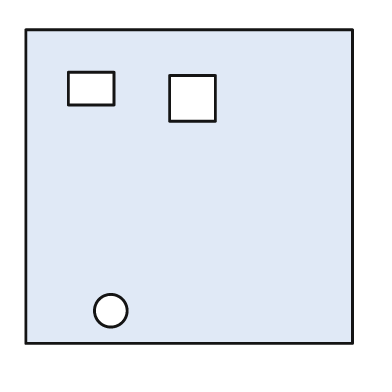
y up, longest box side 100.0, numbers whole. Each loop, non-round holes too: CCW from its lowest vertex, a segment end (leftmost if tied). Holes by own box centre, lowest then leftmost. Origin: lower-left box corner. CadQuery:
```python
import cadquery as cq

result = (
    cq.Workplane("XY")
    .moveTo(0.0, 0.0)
    .lineTo(100.0, 0.0)
    .lineTo(100.0, 96.0)
    .lineTo(0.0, 96.0)
    .close()
    .moveTo(26.0, 10.0)
    .circle(5.0)
    .moveTo(44.0, 68.0)
    .lineTo(58.0, 68.0)
    .lineTo(58.0, 82.0)
    .lineTo(44.0, 82.0)
    .close()
    .moveTo(13.0, 73.0)
    .lineTo(27.0, 73.0)
    .lineTo(27.0, 83.0)
    .lineTo(13.0, 83.0)
    .close()
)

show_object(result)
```